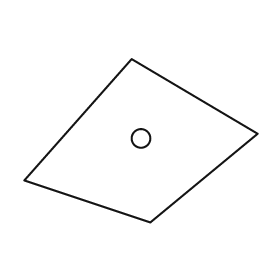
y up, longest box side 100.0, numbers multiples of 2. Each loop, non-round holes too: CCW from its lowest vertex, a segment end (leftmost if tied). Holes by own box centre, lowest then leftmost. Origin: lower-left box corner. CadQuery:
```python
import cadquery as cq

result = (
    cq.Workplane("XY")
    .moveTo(54.0, 0.0)
    .lineTo(100.0, 38.0)
    .lineTo(46.0, 70.0)
    .lineTo(0.0, 18.0)
    .close()
    .moveTo(50.0, 36.0)
    .circle(4.0)
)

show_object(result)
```